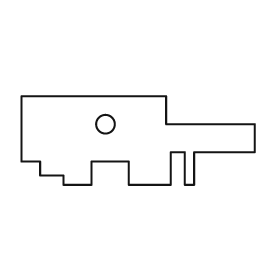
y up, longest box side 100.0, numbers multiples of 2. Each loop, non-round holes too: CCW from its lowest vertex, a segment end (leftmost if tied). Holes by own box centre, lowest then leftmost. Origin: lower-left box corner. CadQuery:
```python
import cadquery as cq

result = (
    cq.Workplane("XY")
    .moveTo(18.0, 0.0)
    .lineTo(30.0, 0.0)
    .lineTo(30.0, 10.0)
    .lineTo(46.0, 10.0)
    .lineTo(46.0, 0.0)
    .lineTo(64.0, 0.0)
    .lineTo(64.0, 14.0)
    .lineTo(70.0, 14.0)
    .lineTo(70.0, 0.0)
    .lineTo(74.0, 0.0)
    .lineTo(74.0, 14.0)
    .lineTo(100.0, 14.0)
    .lineTo(100.0, 26.0)
    .lineTo(62.0, 26.0)
    .lineTo(62.0, 38.0)
    .lineTo(0.0, 38.0)
    .lineTo(0.0, 10.0)
    .lineTo(8.0, 10.0)
    .lineTo(8.0, 4.0)
    .lineTo(18.0, 4.0)
    .close()
    .moveTo(36.0, 26.0)
    .circle(4.0)
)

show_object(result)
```